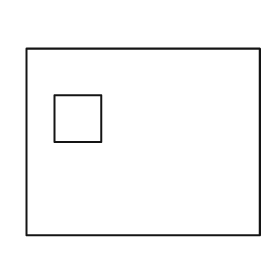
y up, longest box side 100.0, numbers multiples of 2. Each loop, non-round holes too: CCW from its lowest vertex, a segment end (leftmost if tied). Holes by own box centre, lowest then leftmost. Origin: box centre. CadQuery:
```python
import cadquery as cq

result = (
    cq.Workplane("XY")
    .moveTo(-50.0, -40.0)
    .lineTo(50.0, -40.0)
    .lineTo(50.0, 40.0)
    .lineTo(-50.0, 40.0)
    .close()
    .moveTo(-38.0, 0.0)
    .lineTo(-18.0, 0.0)
    .lineTo(-18.0, 20.0)
    .lineTo(-38.0, 20.0)
    .close()
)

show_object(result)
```